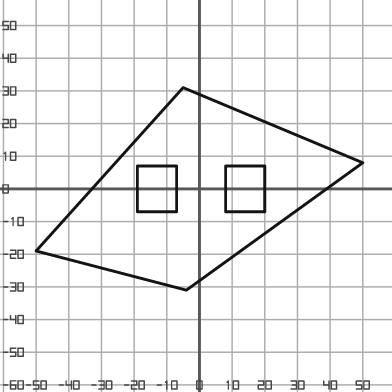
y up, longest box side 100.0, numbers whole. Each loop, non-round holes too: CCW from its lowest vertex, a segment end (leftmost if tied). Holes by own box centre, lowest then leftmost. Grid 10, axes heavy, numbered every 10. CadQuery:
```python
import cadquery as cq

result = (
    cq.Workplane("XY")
    .moveTo(-4.0, -31.0)
    .lineTo(50.0, 8.0)
    .lineTo(-5.0, 31.0)
    .lineTo(-50.0, -19.0)
    .close()
    .moveTo(-19.0, -7.0)
    .lineTo(-7.0, -7.0)
    .lineTo(-7.0, 7.0)
    .lineTo(-19.0, 7.0)
    .close()
    .moveTo(8.0, -7.0)
    .lineTo(20.0, -7.0)
    .lineTo(20.0, 7.0)
    .lineTo(8.0, 7.0)
    .close()
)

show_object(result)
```